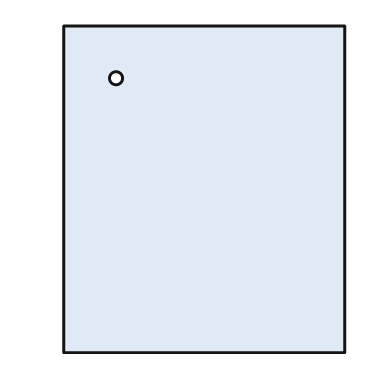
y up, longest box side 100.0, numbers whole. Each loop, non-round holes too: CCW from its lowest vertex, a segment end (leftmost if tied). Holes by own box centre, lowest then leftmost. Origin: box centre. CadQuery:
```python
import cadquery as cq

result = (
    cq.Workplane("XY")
    .moveTo(-43.0, -50.0)
    .lineTo(43.0, -50.0)
    .lineTo(43.0, 50.0)
    .lineTo(-43.0, 50.0)
    .close()
    .moveTo(-27.0, 34.0)
    .circle(2.0)
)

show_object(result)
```